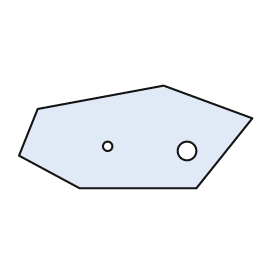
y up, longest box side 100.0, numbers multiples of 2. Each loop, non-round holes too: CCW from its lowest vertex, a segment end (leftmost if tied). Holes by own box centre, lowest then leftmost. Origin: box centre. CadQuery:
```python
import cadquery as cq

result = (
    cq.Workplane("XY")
    .moveTo(-24.0, -22.0)
    .lineTo(26.0, -22.0)
    .lineTo(50.0, 8.0)
    .lineTo(12.0, 22.0)
    .lineTo(-42.0, 12.0)
    .lineTo(-50.0, -8.0)
    .close()
    .moveTo(22.0, -6.0)
    .circle(4.0)
    .moveTo(-12.0, -4.0)
    .circle(2.0)
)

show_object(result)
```